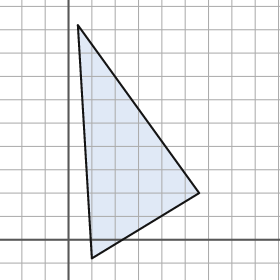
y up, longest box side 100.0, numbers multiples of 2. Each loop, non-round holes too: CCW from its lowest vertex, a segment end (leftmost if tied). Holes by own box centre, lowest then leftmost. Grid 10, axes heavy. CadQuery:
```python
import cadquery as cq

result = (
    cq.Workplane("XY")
    .moveTo(10.0, -8.0)
    .lineTo(56.0, 20.0)
    .lineTo(4.0, 92.0)
    .close()
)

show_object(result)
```